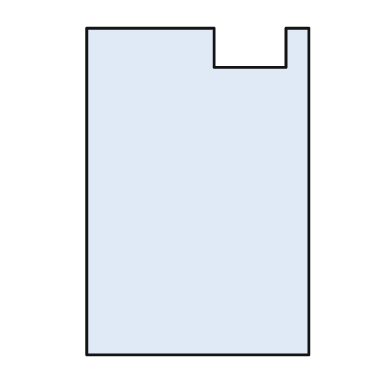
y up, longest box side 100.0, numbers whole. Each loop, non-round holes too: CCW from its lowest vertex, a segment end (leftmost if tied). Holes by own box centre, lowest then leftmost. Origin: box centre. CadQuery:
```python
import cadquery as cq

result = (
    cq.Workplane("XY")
    .moveTo(-34.0, -50.0)
    .lineTo(34.0, -50.0)
    .lineTo(34.0, 50.0)
    .lineTo(27.0, 50.0)
    .lineTo(27.0, 38.0)
    .lineTo(5.0, 38.0)
    .lineTo(5.0, 50.0)
    .lineTo(-34.0, 50.0)
    .close()
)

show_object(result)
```